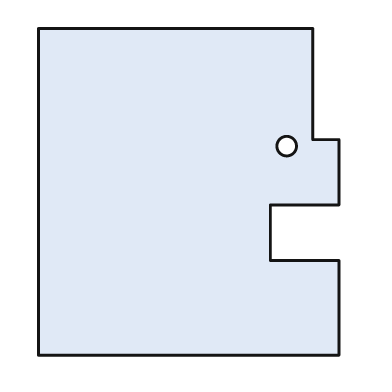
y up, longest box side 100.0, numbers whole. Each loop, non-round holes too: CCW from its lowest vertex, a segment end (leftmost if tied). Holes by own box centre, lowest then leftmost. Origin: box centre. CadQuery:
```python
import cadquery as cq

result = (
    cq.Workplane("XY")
    .moveTo(-46.0, -50.0)
    .lineTo(46.0, -50.0)
    .lineTo(46.0, -21.0)
    .lineTo(25.0, -21.0)
    .lineTo(25.0, -4.0)
    .lineTo(46.0, -4.0)
    .lineTo(46.0, 16.0)
    .lineTo(38.0, 16.0)
    .lineTo(38.0, 50.0)
    .lineTo(-46.0, 50.0)
    .close()
    .moveTo(30.0, 14.0)
    .circle(3.0)
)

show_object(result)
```